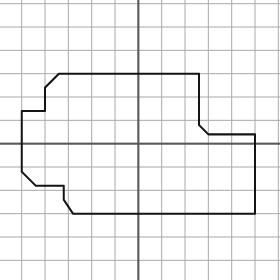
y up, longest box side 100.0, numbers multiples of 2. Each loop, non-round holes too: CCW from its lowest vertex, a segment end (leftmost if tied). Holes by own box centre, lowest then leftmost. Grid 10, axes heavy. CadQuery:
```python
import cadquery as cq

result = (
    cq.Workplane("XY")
    .moveTo(-28.0, -30.0)
    .lineTo(50.0, -30.0)
    .lineTo(50.0, 4.0)
    .lineTo(30.0, 4.0)
    .lineTo(26.0, 8.0)
    .lineTo(26.0, 30.0)
    .lineTo(-34.0, 30.0)
    .lineTo(-40.0, 24.0)
    .lineTo(-40.0, 14.0)
    .lineTo(-50.0, 14.0)
    .lineTo(-50.0, -12.0)
    .lineTo(-44.0, -18.0)
    .lineTo(-32.0, -18.0)
    .lineTo(-32.0, -24.0)
    .close()
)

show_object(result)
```